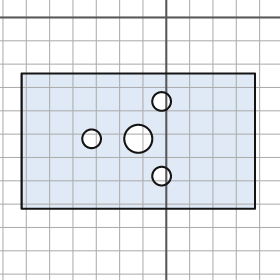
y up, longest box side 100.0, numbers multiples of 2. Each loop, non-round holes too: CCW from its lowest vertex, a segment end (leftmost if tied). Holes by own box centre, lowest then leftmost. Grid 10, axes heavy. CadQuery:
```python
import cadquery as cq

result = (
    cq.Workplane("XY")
    .moveTo(-62.0, -82.0)
    .lineTo(38.0, -82.0)
    .lineTo(38.0, -24.0)
    .lineTo(-62.0, -24.0)
    .close()
    .moveTo(-2.0, -68.0)
    .circle(4.0)
    .moveTo(-32.0, -52.0)
    .circle(4.0)
    .moveTo(-12.0, -52.0)
    .circle(6.0)
    .moveTo(-2.0, -36.0)
    .circle(4.0)
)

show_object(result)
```